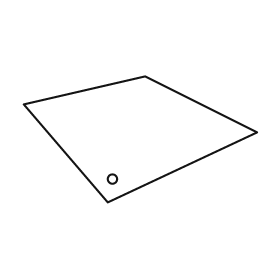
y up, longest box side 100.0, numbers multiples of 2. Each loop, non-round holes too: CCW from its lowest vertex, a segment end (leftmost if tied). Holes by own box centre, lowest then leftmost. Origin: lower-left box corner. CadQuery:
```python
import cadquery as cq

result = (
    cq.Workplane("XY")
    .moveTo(36.0, 0.0)
    .lineTo(100.0, 30.0)
    .lineTo(52.0, 54.0)
    .lineTo(0.0, 42.0)
    .close()
    .moveTo(38.0, 10.0)
    .circle(2.0)
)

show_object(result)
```